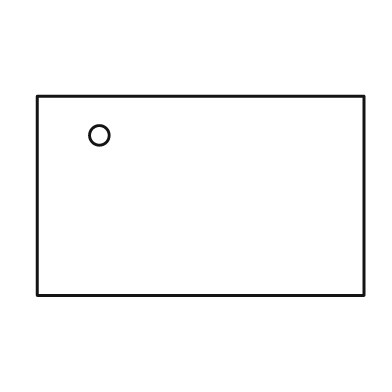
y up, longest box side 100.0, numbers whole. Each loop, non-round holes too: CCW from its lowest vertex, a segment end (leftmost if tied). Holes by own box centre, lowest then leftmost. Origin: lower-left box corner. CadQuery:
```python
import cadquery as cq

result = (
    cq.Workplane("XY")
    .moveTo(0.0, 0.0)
    .lineTo(100.0, 0.0)
    .lineTo(100.0, 61.0)
    .lineTo(0.0, 61.0)
    .close()
    .moveTo(19.0, 49.0)
    .circle(3.0)
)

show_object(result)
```